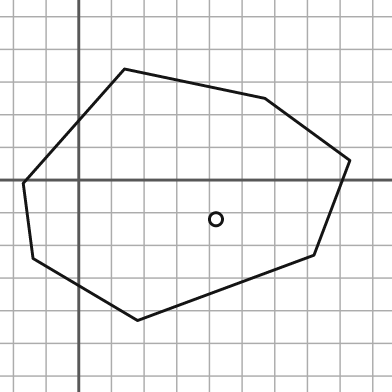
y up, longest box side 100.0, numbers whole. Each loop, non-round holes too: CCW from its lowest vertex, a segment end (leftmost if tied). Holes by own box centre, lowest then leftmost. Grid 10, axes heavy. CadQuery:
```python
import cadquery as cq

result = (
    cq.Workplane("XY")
    .moveTo(18.0, -43.0)
    .lineTo(72.0, -23.0)
    .lineTo(83.0, 6.0)
    .lineTo(57.0, 25.0)
    .lineTo(14.0, 34.0)
    .lineTo(-17.0, -1.0)
    .lineTo(-14.0, -24.0)
    .close()
    .moveTo(42.0, -12.0)
    .circle(2.0)
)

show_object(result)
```